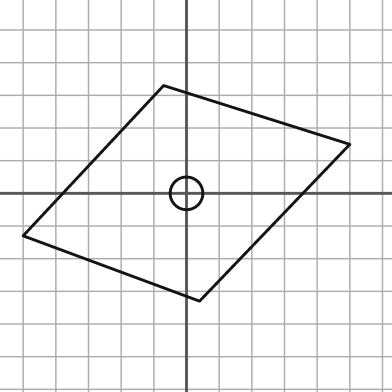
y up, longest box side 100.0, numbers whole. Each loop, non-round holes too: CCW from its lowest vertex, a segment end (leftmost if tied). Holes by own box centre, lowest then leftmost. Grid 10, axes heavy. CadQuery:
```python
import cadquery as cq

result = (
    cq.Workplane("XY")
    .moveTo(4.0, -33.0)
    .lineTo(50.0, 15.0)
    .lineTo(-7.0, 33.0)
    .lineTo(-50.0, -13.0)
    .close()
    .moveTo(0.0, 0.0)
    .circle(5.0)
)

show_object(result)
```